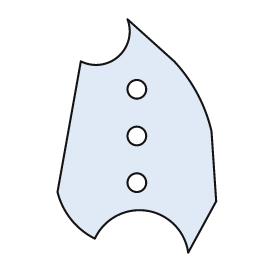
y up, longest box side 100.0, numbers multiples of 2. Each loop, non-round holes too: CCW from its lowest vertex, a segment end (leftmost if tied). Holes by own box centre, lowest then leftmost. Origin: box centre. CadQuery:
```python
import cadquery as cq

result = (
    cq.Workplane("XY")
    .moveTo(22.0, -50.0)
    .lineTo(34.0, -28.0)
    .lineTo(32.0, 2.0)
    .threePointArc((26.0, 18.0), (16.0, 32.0))
    .lineTo(-4.0, 50.0)
    .threePointArc((-8.0, 34.0), (-24.0, 32.0))
    .lineTo(-34.0, -24.0)
    .threePointArc((-28.0, -36.0), (-18.0, -44.0))
    .threePointArc((4.0, -32.0), (22.0, -50.0))
    .close()
    .moveTo(0.0, -20.0)
    .circle(4.0)
    .moveTo(0.0, 0.0)
    .circle(4.0)
    .moveTo(0.0, 20.0)
    .circle(4.0)
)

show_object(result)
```